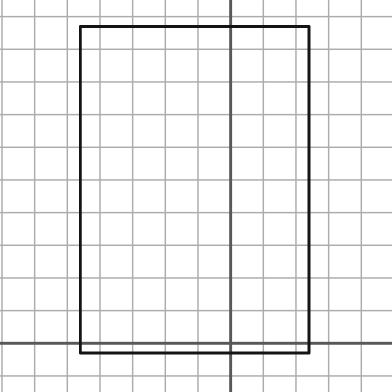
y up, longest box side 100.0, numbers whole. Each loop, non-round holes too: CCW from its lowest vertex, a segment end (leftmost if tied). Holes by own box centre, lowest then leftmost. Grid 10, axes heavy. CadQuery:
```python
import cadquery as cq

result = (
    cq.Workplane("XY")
    .moveTo(-46.0, -3.0)
    .lineTo(24.0, -3.0)
    .lineTo(24.0, 97.0)
    .lineTo(-46.0, 97.0)
    .close()
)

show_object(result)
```